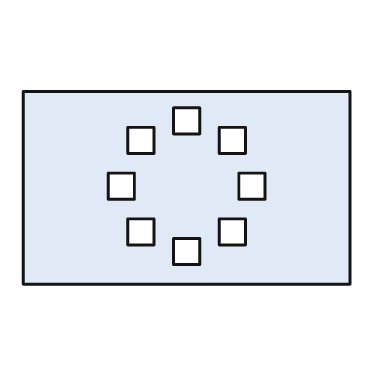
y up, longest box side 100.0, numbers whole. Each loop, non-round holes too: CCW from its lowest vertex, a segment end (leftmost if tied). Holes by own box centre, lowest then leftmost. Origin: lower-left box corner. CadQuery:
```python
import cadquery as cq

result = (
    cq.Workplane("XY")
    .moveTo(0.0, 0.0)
    .lineTo(100.0, 0.0)
    .lineTo(100.0, 59.0)
    .lineTo(0.0, 59.0)
    .close()
    .moveTo(46.0, 6.0)
    .lineTo(54.0, 6.0)
    .lineTo(54.0, 14.0)
    .lineTo(46.0, 14.0)
    .close()
    .moveTo(32.0, 12.0)
    .lineTo(40.0, 12.0)
    .lineTo(40.0, 20.0)
    .lineTo(32.0, 20.0)
    .close()
    .moveTo(60.0, 12.0)
    .lineTo(68.0, 12.0)
    .lineTo(68.0, 20.0)
    .lineTo(60.0, 20.0)
    .close()
    .moveTo(26.0, 26.0)
    .lineTo(34.0, 26.0)
    .lineTo(34.0, 34.0)
    .lineTo(26.0, 34.0)
    .close()
    .moveTo(66.0, 26.0)
    .lineTo(74.0, 26.0)
    .lineTo(74.0, 34.0)
    .lineTo(66.0, 34.0)
    .close()
    .moveTo(32.0, 40.0)
    .lineTo(40.0, 40.0)
    .lineTo(40.0, 48.0)
    .lineTo(32.0, 48.0)
    .close()
    .moveTo(60.0, 40.0)
    .lineTo(68.0, 40.0)
    .lineTo(68.0, 48.0)
    .lineTo(60.0, 48.0)
    .close()
    .moveTo(46.0, 46.0)
    .lineTo(54.0, 46.0)
    .lineTo(54.0, 54.0)
    .lineTo(46.0, 54.0)
    .close()
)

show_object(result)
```